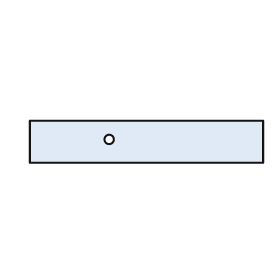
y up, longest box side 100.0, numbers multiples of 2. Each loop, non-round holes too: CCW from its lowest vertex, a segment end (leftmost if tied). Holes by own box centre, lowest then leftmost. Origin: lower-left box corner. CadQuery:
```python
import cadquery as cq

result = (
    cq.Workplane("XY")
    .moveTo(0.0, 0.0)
    .lineTo(100.0, 0.0)
    .lineTo(100.0, 18.0)
    .lineTo(0.0, 18.0)
    .close()
    .moveTo(34.0, 10.0)
    .circle(2.0)
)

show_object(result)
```